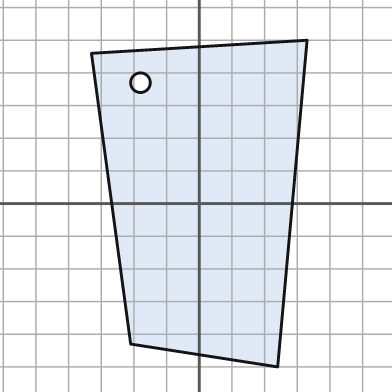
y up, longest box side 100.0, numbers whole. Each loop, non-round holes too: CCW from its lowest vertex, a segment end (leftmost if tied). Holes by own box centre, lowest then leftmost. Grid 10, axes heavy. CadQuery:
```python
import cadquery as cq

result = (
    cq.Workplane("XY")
    .moveTo(24.0, -50.0)
    .lineTo(33.0, 50.0)
    .lineTo(-33.0, 46.0)
    .lineTo(-21.0, -43.0)
    .close()
    .moveTo(-18.0, 37.0)
    .circle(3.0)
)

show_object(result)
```